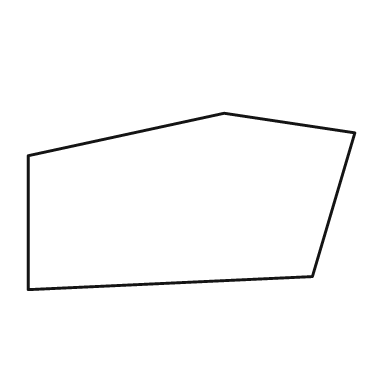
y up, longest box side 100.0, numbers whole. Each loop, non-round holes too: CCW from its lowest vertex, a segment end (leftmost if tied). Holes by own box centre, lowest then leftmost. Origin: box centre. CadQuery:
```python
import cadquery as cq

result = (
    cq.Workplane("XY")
    .moveTo(-50.0, -27.0)
    .lineTo(37.0, -23.0)
    .lineTo(50.0, 21.0)
    .lineTo(10.0, 27.0)
    .lineTo(-50.0, 14.0)
    .close()
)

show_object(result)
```